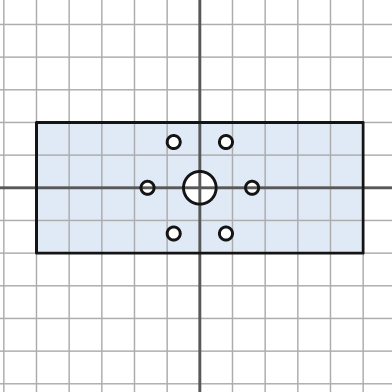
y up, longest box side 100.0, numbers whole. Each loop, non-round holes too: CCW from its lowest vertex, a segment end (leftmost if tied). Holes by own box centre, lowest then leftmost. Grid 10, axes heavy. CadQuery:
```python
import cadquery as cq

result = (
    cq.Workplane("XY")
    .moveTo(-50.0, -20.0)
    .lineTo(50.0, -20.0)
    .lineTo(50.0, 20.0)
    .lineTo(-50.0, 20.0)
    .close()
    .moveTo(-8.0, -14.0)
    .circle(2.0)
    .moveTo(8.0, -14.0)
    .circle(2.0)
    .moveTo(-16.0, 0.0)
    .circle(2.0)
    .moveTo(0.0, 0.0)
    .circle(5.0)
    .moveTo(16.0, 0.0)
    .circle(2.0)
    .moveTo(-8.0, 14.0)
    .circle(2.0)
    .moveTo(8.0, 14.0)
    .circle(2.0)
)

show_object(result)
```